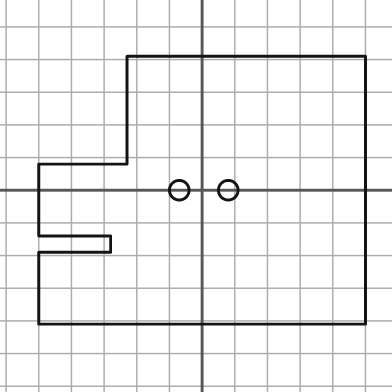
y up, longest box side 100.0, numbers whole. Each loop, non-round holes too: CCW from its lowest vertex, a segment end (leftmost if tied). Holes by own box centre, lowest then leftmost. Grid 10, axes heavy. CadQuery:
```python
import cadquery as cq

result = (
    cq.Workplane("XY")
    .moveTo(-50.0, -41.0)
    .lineTo(50.0, -41.0)
    .lineTo(50.0, 41.0)
    .lineTo(-23.0, 41.0)
    .lineTo(-23.0, 8.0)
    .lineTo(-50.0, 8.0)
    .lineTo(-50.0, -14.0)
    .lineTo(-28.0, -14.0)
    .lineTo(-28.0, -19.0)
    .lineTo(-50.0, -19.0)
    .close()
    .moveTo(-7.0, 0.0)
    .circle(3.0)
    .moveTo(8.0, 0.0)
    .circle(3.0)
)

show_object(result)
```